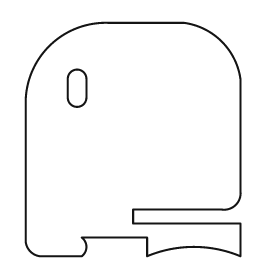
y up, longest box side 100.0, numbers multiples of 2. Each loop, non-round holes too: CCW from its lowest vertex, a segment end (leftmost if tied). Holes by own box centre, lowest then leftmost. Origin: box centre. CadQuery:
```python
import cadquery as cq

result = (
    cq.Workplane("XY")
    .moveTo(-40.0, -50.0)
    .lineTo(-22.0, -50.0)
    .threePointArc((-20.0, -46.0), (-22.0, -42.0))
    .lineTo(6.0, -42.0)
    .lineTo(6.0, -50.0)
    .threePointArc((26.0, -46.0), (46.0, -50.0))
    .lineTo(46.0, -36.0)
    .lineTo(0.0, -36.0)
    .lineTo(0.0, -30.0)
    .lineTo(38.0, -30.0)
    .threePointArc((44.0, -28.0), (46.0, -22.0))
    .lineTo(46.0, 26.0)
    .threePointArc((38.0, 42.0), (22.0, 50.0))
    .lineTo(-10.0, 50.0)
    .threePointArc((-36.0, 40.0), (-46.0, 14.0))
    .lineTo(-46.0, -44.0)
    .threePointArc((-44.0, -48.0), (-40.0, -50.0))
    .close()
    .moveTo(-28.0, 18.0)
    .threePointArc((-24.0, 14.0), (-20.0, 18.0))
    .lineTo(-20.0, 26.0)
    .threePointArc((-24.0, 30.0), (-28.0, 26.0))
    .close()
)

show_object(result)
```